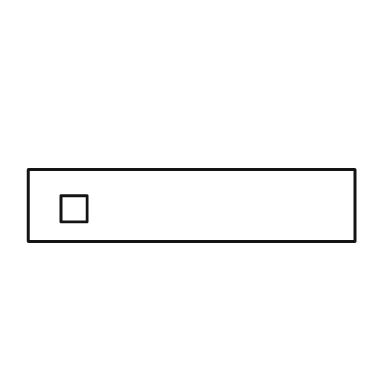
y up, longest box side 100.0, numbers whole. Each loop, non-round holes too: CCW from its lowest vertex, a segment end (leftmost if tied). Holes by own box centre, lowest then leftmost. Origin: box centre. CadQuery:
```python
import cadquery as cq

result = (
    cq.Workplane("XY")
    .moveTo(-50.0, -11.0)
    .lineTo(50.0, -11.0)
    .lineTo(50.0, 11.0)
    .lineTo(-50.0, 11.0)
    .close()
    .moveTo(-40.0, -5.0)
    .lineTo(-32.0, -5.0)
    .lineTo(-32.0, 3.0)
    .lineTo(-40.0, 3.0)
    .close()
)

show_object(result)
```